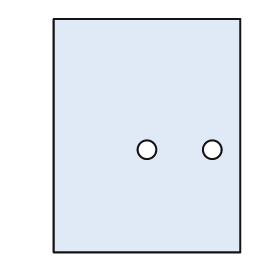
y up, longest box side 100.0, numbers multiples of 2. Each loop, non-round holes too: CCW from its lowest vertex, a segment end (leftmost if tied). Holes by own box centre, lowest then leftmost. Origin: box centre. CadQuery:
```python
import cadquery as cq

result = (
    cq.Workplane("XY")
    .moveTo(-40.0, -50.0)
    .lineTo(40.0, -50.0)
    .lineTo(40.0, 50.0)
    .lineTo(-40.0, 50.0)
    .close()
    .moveTo(0.0, -6.0)
    .circle(4.0)
    .moveTo(28.0, -6.0)
    .circle(4.0)
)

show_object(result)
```